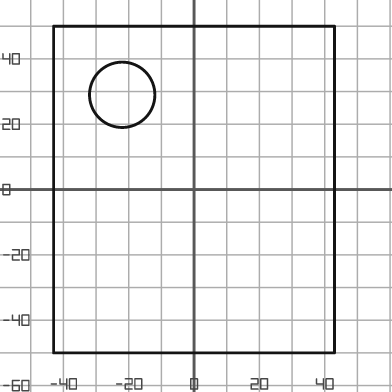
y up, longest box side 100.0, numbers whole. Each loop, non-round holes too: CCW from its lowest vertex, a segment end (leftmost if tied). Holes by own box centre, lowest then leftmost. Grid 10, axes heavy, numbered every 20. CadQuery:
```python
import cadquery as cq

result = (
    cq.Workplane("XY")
    .moveTo(-43.0, -50.0)
    .lineTo(43.0, -50.0)
    .lineTo(43.0, 50.0)
    .lineTo(-43.0, 50.0)
    .close()
    .moveTo(-22.0, 29.0)
    .circle(10.0)
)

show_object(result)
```